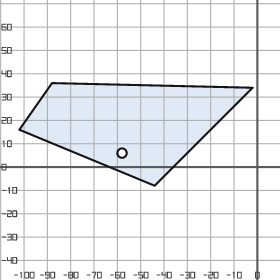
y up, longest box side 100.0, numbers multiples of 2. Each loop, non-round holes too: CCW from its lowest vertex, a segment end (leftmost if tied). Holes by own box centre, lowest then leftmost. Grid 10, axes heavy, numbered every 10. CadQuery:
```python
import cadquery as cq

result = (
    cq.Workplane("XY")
    .moveTo(-44.0, -8.0)
    .lineTo(-2.0, 34.0)
    .lineTo(-88.0, 36.0)
    .lineTo(-102.0, 16.0)
    .close()
    .moveTo(-58.0, 6.0)
    .circle(2.0)
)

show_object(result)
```